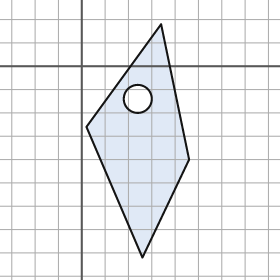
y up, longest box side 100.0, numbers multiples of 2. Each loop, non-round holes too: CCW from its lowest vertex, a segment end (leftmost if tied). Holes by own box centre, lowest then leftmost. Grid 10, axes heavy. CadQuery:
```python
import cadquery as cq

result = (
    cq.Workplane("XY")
    .moveTo(26.0, -82.0)
    .lineTo(46.0, -40.0)
    .lineTo(34.0, 18.0)
    .lineTo(2.0, -26.0)
    .close()
    .moveTo(24.0, -14.0)
    .circle(6.0)
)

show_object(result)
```